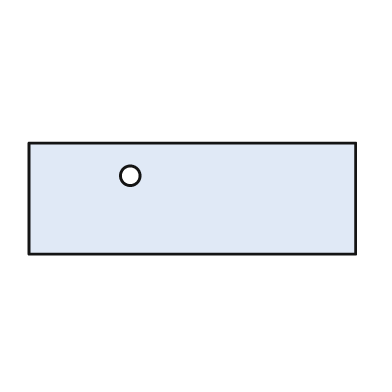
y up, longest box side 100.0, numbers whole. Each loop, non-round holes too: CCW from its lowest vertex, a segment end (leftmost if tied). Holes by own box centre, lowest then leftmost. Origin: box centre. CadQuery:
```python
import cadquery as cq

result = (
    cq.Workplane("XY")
    .moveTo(-50.0, -17.0)
    .lineTo(50.0, -17.0)
    .lineTo(50.0, 17.0)
    .lineTo(-50.0, 17.0)
    .close()
    .moveTo(-19.0, 7.0)
    .circle(3.0)
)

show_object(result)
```